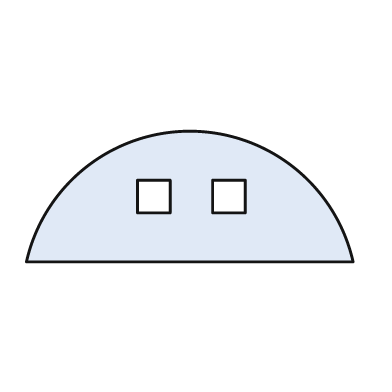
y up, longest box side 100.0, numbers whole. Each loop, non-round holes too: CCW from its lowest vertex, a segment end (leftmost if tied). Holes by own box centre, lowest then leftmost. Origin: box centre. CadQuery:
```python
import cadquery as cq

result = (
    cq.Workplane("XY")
    .moveTo(-50.0, -20.0)
    .lineTo(50.0, -20.0)
    .threePointArc((0.0, 20.0), (-50.0, -20.0))
    .close()
    .moveTo(-16.0, -5.0)
    .lineTo(-6.0, -5.0)
    .lineTo(-6.0, 5.0)
    .lineTo(-16.0, 5.0)
    .close()
    .moveTo(7.0, -5.0)
    .lineTo(17.0, -5.0)
    .lineTo(17.0, 5.0)
    .lineTo(7.0, 5.0)
    .close()
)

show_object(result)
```